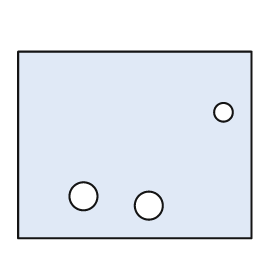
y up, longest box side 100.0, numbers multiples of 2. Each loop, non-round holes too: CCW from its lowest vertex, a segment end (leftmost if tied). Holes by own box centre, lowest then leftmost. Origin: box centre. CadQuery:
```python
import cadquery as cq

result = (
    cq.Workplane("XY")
    .moveTo(-50.0, -40.0)
    .lineTo(50.0, -40.0)
    .lineTo(50.0, 40.0)
    .lineTo(-50.0, 40.0)
    .close()
    .moveTo(6.0, -26.0)
    .circle(6.0)
    .moveTo(-22.0, -22.0)
    .circle(6.0)
    .moveTo(38.0, 14.0)
    .circle(4.0)
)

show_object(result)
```